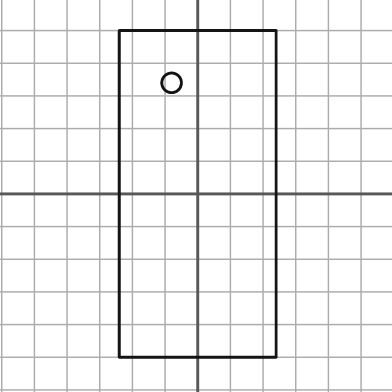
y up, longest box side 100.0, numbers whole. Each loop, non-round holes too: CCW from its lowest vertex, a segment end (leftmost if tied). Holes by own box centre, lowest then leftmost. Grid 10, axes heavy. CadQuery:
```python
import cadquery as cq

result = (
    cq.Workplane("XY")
    .moveTo(-24.0, -50.0)
    .lineTo(24.0, -50.0)
    .lineTo(24.0, 50.0)
    .lineTo(-24.0, 50.0)
    .close()
    .moveTo(-8.0, 34.0)
    .circle(3.0)
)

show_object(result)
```